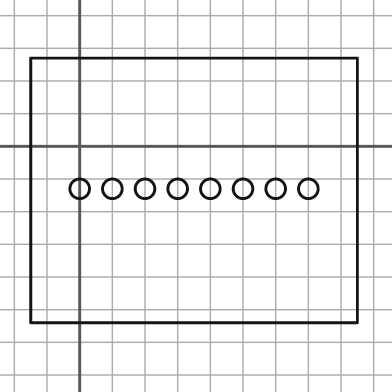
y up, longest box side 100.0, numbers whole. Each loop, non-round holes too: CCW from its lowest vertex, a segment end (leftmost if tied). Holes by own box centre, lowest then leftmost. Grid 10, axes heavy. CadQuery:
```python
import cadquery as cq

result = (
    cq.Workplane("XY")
    .moveTo(-15.0, -54.0)
    .lineTo(85.0, -54.0)
    .lineTo(85.0, 27.0)
    .lineTo(-15.0, 27.0)
    .close()
    .moveTo(0.0, -13.0)
    .circle(3.0)
    .moveTo(10.0, -13.0)
    .circle(3.0)
    .moveTo(20.0, -13.0)
    .circle(3.0)
    .moveTo(30.0, -13.0)
    .circle(3.0)
    .moveTo(40.0, -13.0)
    .circle(3.0)
    .moveTo(50.0, -13.0)
    .circle(3.0)
    .moveTo(60.0, -13.0)
    .circle(3.0)
    .moveTo(70.0, -13.0)
    .circle(3.0)
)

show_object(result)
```